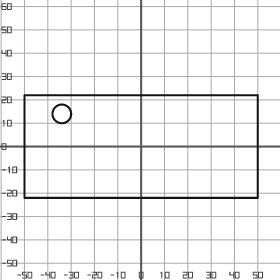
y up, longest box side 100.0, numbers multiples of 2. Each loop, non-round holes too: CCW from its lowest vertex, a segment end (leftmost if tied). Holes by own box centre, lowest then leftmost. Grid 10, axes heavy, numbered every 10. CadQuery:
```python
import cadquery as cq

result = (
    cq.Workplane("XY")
    .moveTo(-50.0, -22.0)
    .lineTo(50.0, -22.0)
    .lineTo(50.0, 22.0)
    .lineTo(-50.0, 22.0)
    .close()
    .moveTo(-34.0, 14.0)
    .circle(4.0)
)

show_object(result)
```